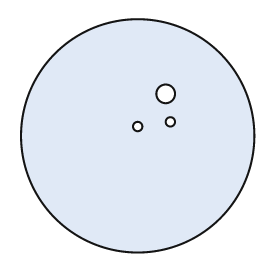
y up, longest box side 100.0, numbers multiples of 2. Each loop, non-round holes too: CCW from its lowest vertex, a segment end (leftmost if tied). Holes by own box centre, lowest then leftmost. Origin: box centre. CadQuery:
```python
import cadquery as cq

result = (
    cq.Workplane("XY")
    .moveTo(0.0, 0.0)
    .circle(50.0)
    .moveTo(0.0, 4.0)
    .circle(2.0)
    .moveTo(14.0, 6.0)
    .circle(2.0)
    .moveTo(12.0, 18.0)
    .circle(4.0)
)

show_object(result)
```